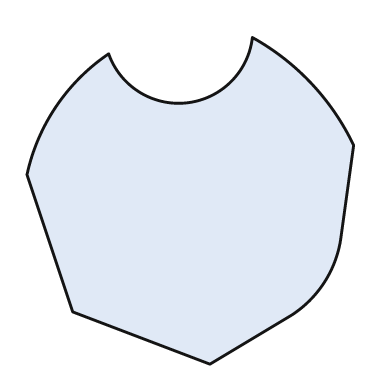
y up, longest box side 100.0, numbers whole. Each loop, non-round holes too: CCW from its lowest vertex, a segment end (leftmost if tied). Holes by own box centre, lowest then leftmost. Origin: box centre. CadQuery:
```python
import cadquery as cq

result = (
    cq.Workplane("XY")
    .moveTo(6.0, -50.0)
    .lineTo(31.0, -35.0)
    .threePointArc((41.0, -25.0), (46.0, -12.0))
    .lineTo(50.0, 17.0)
    .threePointArc((37.0, 36.0), (19.0, 50.0))
    .threePointArc((-1.0, 30.0), (-25.0, 45.0))
    .threePointArc((-41.0, 29.0), (-50.0, 8.0))
    .lineTo(-36.0, -34.0)
    .close()
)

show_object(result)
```